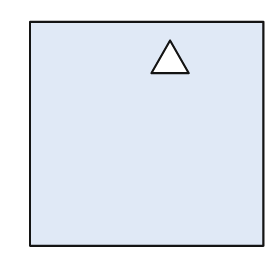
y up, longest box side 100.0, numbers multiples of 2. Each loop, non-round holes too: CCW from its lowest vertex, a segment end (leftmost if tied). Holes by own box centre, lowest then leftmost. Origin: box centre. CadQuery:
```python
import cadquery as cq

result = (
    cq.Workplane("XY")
    .moveTo(-50.0, -48.0)
    .lineTo(50.0, -48.0)
    .lineTo(50.0, 48.0)
    .lineTo(-50.0, 48.0)
    .close()
    .moveTo(2.0, 26.0)
    .lineTo(18.0, 26.0)
    .lineTo(10.0, 40.0)
    .close()
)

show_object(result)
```